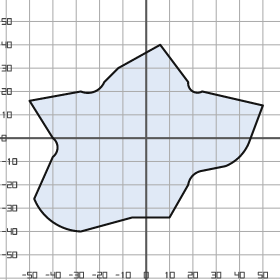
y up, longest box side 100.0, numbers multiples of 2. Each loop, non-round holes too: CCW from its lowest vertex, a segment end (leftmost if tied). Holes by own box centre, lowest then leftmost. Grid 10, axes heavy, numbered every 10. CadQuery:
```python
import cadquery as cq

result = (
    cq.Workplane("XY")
    .moveTo(-28.0, -40.0)
    .lineTo(-6.0, -34.0)
    .lineTo(10.0, -34.0)
    .lineTo(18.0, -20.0)
    .threePointArc((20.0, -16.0), (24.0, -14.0))
    .lineTo(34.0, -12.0)
    .threePointArc((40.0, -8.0), (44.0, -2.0))
    .lineTo(50.0, 14.0)
    .lineTo(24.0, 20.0)
    .threePointArc((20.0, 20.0), (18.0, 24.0))
    .lineTo(6.0, 40.0)
    .lineTo(-12.0, 30.0)
    .lineTo(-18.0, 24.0)
    .threePointArc((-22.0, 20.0), (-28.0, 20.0))
    .lineTo(-50.0, 16.0)
    .lineTo(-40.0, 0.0)
    .threePointArc((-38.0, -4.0), (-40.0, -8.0))
    .lineTo(-48.0, -26.0)
    .threePointArc((-40.0, -36.0), (-28.0, -40.0))
    .close()
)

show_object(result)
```